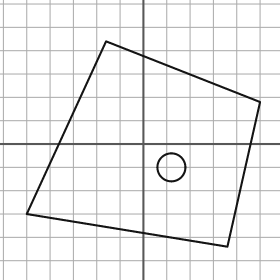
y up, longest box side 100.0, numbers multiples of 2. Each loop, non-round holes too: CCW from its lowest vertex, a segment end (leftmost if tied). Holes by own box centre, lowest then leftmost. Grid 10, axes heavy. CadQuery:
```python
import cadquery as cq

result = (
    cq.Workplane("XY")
    .moveTo(36.0, -44.0)
    .lineTo(50.0, 18.0)
    .lineTo(-16.0, 44.0)
    .lineTo(-50.0, -30.0)
    .close()
    .moveTo(12.0, -10.0)
    .circle(6.0)
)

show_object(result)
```